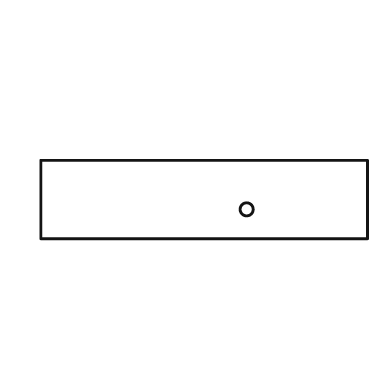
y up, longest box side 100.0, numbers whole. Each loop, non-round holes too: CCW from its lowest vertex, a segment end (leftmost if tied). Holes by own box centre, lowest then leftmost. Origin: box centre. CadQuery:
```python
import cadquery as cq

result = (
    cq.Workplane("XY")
    .moveTo(-50.0, -12.0)
    .lineTo(50.0, -12.0)
    .lineTo(50.0, 12.0)
    .lineTo(-50.0, 12.0)
    .close()
    .moveTo(13.0, -3.0)
    .circle(2.0)
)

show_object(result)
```